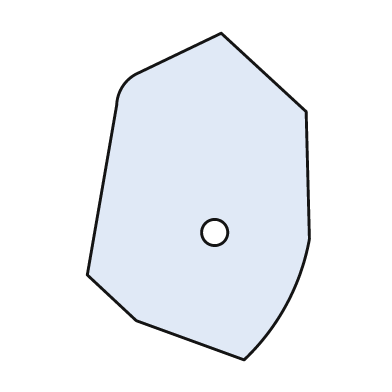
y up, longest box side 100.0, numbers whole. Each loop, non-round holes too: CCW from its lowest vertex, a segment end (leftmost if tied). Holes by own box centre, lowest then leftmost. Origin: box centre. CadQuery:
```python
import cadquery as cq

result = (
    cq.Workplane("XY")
    .moveTo(14.0, -50.0)
    .threePointArc((27.0, -33.0), (34.0, -13.0))
    .lineTo(33.0, 26.0)
    .lineTo(7.0, 50.0)
    .lineTo(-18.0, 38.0)
    .threePointArc((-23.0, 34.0), (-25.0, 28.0))
    .lineTo(-34.0, -24.0)
    .lineTo(-19.0, -38.0)
    .close()
    .moveTo(5.0, -11.0)
    .circle(4.0)
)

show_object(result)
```